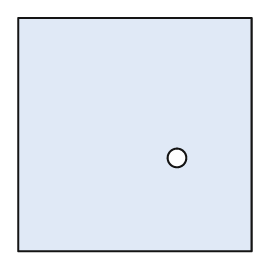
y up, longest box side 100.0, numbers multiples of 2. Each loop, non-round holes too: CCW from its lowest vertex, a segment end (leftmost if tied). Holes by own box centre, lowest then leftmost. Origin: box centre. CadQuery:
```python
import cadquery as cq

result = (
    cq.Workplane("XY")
    .moveTo(-50.0, -50.0)
    .lineTo(50.0, -50.0)
    .lineTo(50.0, 50.0)
    .lineTo(-50.0, 50.0)
    .close()
    .moveTo(18.0, -10.0)
    .circle(4.0)
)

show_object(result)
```